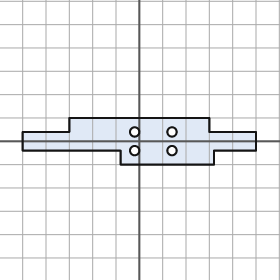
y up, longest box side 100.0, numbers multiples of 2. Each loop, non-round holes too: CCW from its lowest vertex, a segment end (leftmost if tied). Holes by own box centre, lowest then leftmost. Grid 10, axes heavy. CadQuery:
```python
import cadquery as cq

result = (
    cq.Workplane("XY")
    .moveTo(-8.0, -10.0)
    .lineTo(32.0, -10.0)
    .lineTo(32.0, -4.0)
    .lineTo(50.0, -4.0)
    .lineTo(50.0, 4.0)
    .lineTo(30.0, 4.0)
    .lineTo(30.0, 10.0)
    .lineTo(-30.0, 10.0)
    .lineTo(-30.0, 4.0)
    .lineTo(-50.0, 4.0)
    .lineTo(-50.0, -4.0)
    .lineTo(-8.0, -4.0)
    .close()
    .moveTo(-2.0, -4.0)
    .circle(2.0)
    .moveTo(14.0, -4.0)
    .circle(2.0)
    .moveTo(-2.0, 4.0)
    .circle(2.0)
    .moveTo(14.0, 4.0)
    .circle(2.0)
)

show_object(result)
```